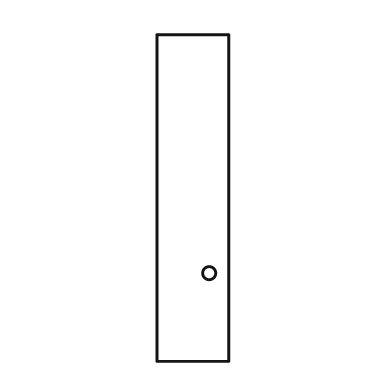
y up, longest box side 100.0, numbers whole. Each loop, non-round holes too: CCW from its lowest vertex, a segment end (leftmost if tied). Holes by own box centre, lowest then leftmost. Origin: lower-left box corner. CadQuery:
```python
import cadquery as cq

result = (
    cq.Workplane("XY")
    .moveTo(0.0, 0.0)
    .lineTo(22.0, 0.0)
    .lineTo(22.0, 100.0)
    .lineTo(0.0, 100.0)
    .close()
    .moveTo(16.0, 27.0)
    .circle(2.0)
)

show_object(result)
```